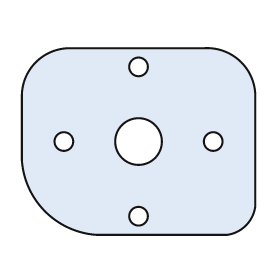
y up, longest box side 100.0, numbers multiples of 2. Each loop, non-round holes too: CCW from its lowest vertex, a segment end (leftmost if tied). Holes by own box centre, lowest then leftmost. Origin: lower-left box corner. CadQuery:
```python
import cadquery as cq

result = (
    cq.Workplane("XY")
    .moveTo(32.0, 0.0)
    .lineTo(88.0, 0.0)
    .threePointArc((96.0, 4.0), (100.0, 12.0))
    .lineTo(100.0, 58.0)
    .threePointArc((94.0, 74.0), (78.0, 80.0))
    .lineTo(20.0, 80.0)
    .threePointArc((6.0, 74.0), (0.0, 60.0))
    .lineTo(0.0, 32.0)
    .threePointArc((10.0, 10.0), (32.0, 0.0))
    .close()
    .moveTo(50.0, 8.0)
    .circle(4.0)
    .moveTo(18.0, 40.0)
    .circle(4.0)
    .moveTo(50.0, 40.0)
    .circle(10.0)
    .moveTo(82.0, 40.0)
    .circle(4.0)
    .moveTo(50.0, 72.0)
    .circle(4.0)
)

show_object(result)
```